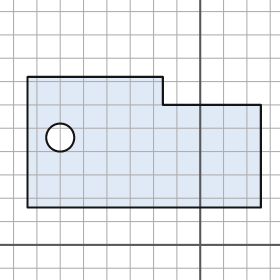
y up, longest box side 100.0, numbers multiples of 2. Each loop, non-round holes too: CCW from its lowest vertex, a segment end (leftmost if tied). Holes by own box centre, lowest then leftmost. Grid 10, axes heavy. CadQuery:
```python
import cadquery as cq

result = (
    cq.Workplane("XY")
    .moveTo(-74.0, 16.0)
    .lineTo(26.0, 16.0)
    .lineTo(26.0, 60.0)
    .lineTo(-16.0, 60.0)
    .lineTo(-16.0, 72.0)
    .lineTo(-74.0, 72.0)
    .close()
    .moveTo(-60.0, 46.0)
    .circle(6.0)
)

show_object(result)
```